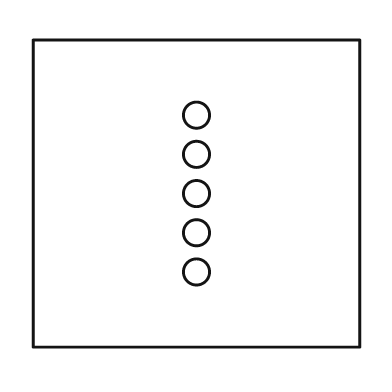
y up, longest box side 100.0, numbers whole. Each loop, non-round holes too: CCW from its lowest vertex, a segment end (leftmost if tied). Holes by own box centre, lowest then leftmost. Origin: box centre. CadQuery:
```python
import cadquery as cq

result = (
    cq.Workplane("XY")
    .moveTo(-50.0, -47.0)
    .lineTo(50.0, -47.0)
    .lineTo(50.0, 47.0)
    .lineTo(-50.0, 47.0)
    .close()
    .moveTo(0.0, -24.0)
    .circle(4.0)
    .moveTo(0.0, -12.0)
    .circle(4.0)
    .moveTo(0.0, 0.0)
    .circle(4.0)
    .moveTo(0.0, 12.0)
    .circle(4.0)
    .moveTo(0.0, 24.0)
    .circle(4.0)
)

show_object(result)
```